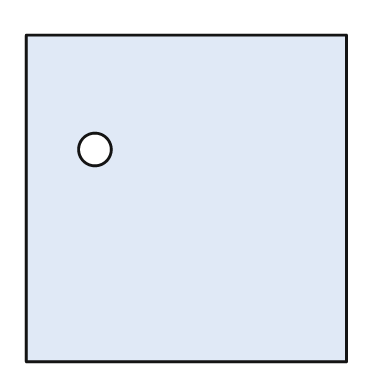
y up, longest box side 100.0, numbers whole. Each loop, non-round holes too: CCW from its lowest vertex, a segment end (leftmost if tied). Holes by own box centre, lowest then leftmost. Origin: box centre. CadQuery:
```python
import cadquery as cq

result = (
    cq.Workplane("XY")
    .moveTo(-49.0, -50.0)
    .lineTo(49.0, -50.0)
    .lineTo(49.0, 50.0)
    .lineTo(-49.0, 50.0)
    .close()
    .moveTo(-28.0, 15.0)
    .circle(5.0)
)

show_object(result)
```